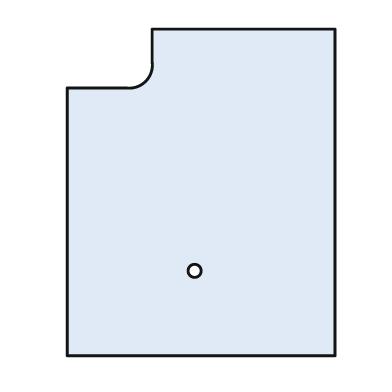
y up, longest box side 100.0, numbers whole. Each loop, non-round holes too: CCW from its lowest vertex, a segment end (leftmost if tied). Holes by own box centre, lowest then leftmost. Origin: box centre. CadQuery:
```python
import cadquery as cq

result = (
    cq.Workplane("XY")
    .moveTo(-41.0, -50.0)
    .lineTo(41.0, -50.0)
    .lineTo(41.0, 50.0)
    .lineTo(-15.0, 50.0)
    .lineTo(-15.0, 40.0)
    .threePointArc((-17.0, 34.0), (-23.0, 32.0))
    .lineTo(-41.0, 32.0)
    .close()
    .moveTo(-2.0, -24.0)
    .circle(2.0)
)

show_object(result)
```